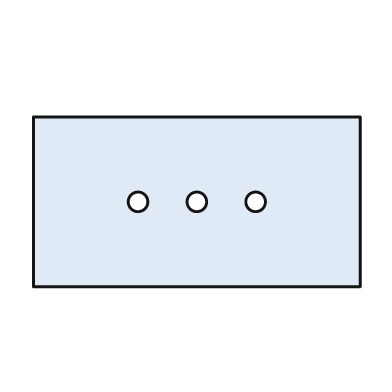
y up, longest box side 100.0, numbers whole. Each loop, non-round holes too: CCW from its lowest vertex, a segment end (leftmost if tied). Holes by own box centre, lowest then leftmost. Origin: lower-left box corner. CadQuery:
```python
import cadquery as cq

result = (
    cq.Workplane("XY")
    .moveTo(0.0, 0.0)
    .lineTo(100.0, 0.0)
    .lineTo(100.0, 52.0)
    .lineTo(0.0, 52.0)
    .close()
    .moveTo(32.0, 26.0)
    .circle(3.0)
    .moveTo(50.0, 26.0)
    .circle(3.0)
    .moveTo(68.0, 26.0)
    .circle(3.0)
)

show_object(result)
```